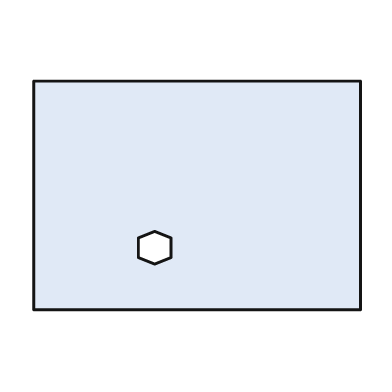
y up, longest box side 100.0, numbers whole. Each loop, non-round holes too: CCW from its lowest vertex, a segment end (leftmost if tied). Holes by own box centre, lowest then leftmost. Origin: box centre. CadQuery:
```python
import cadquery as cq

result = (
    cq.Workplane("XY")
    .moveTo(-50.0, -35.0)
    .lineTo(50.0, -35.0)
    .lineTo(50.0, 35.0)
    .lineTo(-50.0, 35.0)
    .close()
    .moveTo(-13.0, -21.0)
    .lineTo(-8.0, -19.0)
    .lineTo(-8.0, -13.0)
    .lineTo(-13.0, -11.0)
    .lineTo(-18.0, -13.0)
    .lineTo(-18.0, -19.0)
    .close()
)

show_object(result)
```